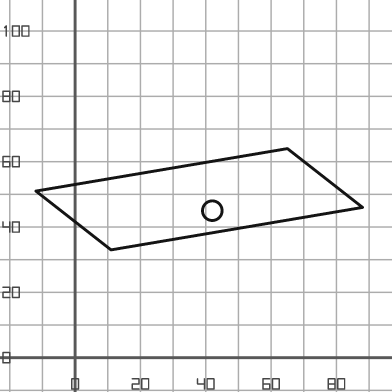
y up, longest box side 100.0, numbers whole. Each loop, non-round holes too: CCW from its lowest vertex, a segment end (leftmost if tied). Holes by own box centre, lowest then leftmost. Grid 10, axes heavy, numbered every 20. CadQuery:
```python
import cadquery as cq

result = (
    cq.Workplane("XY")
    .moveTo(11.0, 33.0)
    .lineTo(88.0, 46.0)
    .lineTo(65.0, 64.0)
    .lineTo(-12.0, 51.0)
    .close()
    .moveTo(42.0, 45.0)
    .circle(3.0)
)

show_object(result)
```